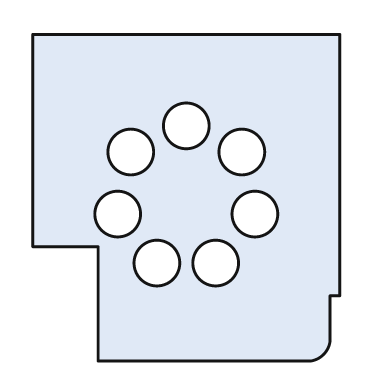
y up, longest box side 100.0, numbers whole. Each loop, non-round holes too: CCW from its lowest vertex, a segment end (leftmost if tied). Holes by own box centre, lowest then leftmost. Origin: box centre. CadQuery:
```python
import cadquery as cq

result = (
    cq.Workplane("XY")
    .moveTo(-27.0, -50.0)
    .lineTo(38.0, -50.0)
    .threePointArc((42.0, -48.0), (44.0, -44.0))
    .lineTo(44.0, -30.0)
    .lineTo(47.0, -30.0)
    .lineTo(47.0, 50.0)
    .lineTo(-47.0, 50.0)
    .lineTo(-47.0, -15.0)
    .lineTo(-27.0, -15.0)
    .close()
    .moveTo(-9.0, -20.0)
    .circle(7.0)
    .moveTo(9.0, -20.0)
    .circle(7.0)
    .moveTo(-21.0, -5.0)
    .circle(7.0)
    .moveTo(21.0, -5.0)
    .circle(7.0)
    .moveTo(-17.0, 14.0)
    .circle(7.0)
    .moveTo(17.0, 14.0)
    .circle(7.0)
    .moveTo(0.0, 22.0)
    .circle(7.0)
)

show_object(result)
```